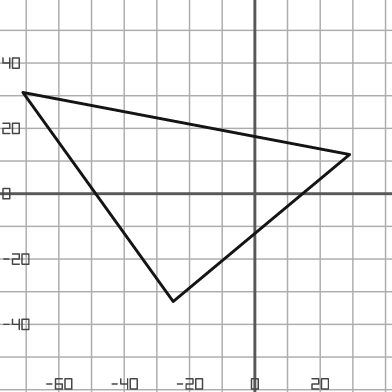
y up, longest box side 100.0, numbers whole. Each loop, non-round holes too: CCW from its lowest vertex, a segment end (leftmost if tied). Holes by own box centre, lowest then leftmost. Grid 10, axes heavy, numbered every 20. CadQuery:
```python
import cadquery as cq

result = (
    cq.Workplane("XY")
    .moveTo(-25.0, -33.0)
    .lineTo(29.0, 12.0)
    .lineTo(-71.0, 31.0)
    .close()
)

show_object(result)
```